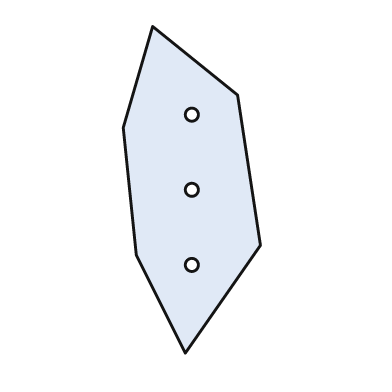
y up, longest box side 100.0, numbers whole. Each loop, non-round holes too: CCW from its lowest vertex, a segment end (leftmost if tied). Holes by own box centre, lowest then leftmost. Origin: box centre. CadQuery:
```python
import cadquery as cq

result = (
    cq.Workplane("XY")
    .moveTo(-2.0, -50.0)
    .lineTo(21.0, -17.0)
    .lineTo(14.0, 29.0)
    .lineTo(-12.0, 50.0)
    .lineTo(-21.0, 19.0)
    .lineTo(-17.0, -20.0)
    .close()
    .moveTo(0.0, -23.0)
    .circle(2.0)
    .moveTo(0.0, 0.0)
    .circle(2.0)
    .moveTo(0.0, 23.0)
    .circle(2.0)
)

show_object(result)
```